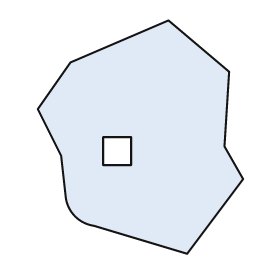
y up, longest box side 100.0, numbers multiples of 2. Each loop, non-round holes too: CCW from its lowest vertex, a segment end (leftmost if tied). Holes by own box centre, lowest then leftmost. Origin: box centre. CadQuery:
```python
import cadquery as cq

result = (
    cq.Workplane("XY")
    .moveTo(20.0, -50.0)
    .lineTo(44.0, -18.0)
    .lineTo(36.0, -4.0)
    .lineTo(38.0, 28.0)
    .lineTo(12.0, 50.0)
    .lineTo(-30.0, 32.0)
    .lineTo(-44.0, 12.0)
    .lineTo(-34.0, -8.0)
    .lineTo(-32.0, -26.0)
    .threePointArc((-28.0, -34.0), (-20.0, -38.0))
    .close()
    .moveTo(-16.0, -12.0)
    .lineTo(-4.0, -12.0)
    .lineTo(-4.0, 0.0)
    .lineTo(-16.0, 0.0)
    .close()
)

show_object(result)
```